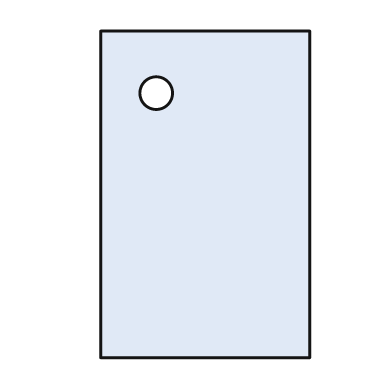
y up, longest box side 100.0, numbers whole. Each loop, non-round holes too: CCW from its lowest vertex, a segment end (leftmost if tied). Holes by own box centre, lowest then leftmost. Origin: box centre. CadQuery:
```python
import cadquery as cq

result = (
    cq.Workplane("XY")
    .moveTo(-32.0, -50.0)
    .lineTo(32.0, -50.0)
    .lineTo(32.0, 50.0)
    .lineTo(-32.0, 50.0)
    .close()
    .moveTo(-15.0, 31.0)
    .circle(5.0)
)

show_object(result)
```